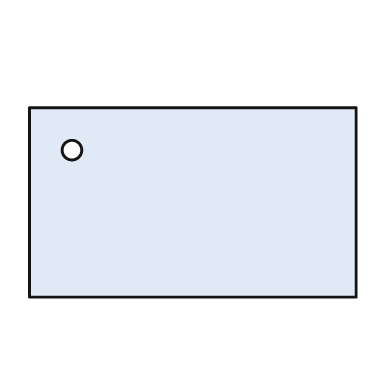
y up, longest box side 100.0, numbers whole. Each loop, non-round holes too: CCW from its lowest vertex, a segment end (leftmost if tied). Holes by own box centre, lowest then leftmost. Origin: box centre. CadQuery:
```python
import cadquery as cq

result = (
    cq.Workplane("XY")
    .moveTo(-50.0, -29.0)
    .lineTo(50.0, -29.0)
    .lineTo(50.0, 29.0)
    .lineTo(-50.0, 29.0)
    .close()
    .moveTo(-37.0, 16.0)
    .circle(3.0)
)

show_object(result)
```